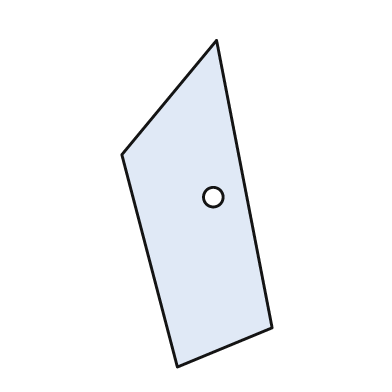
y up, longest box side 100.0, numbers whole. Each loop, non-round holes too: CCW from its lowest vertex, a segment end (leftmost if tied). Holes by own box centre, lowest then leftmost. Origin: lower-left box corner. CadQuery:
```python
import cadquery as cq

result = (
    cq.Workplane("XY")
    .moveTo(17.0, 0.0)
    .lineTo(46.0, 12.0)
    .lineTo(29.0, 100.0)
    .lineTo(0.0, 65.0)
    .close()
    .moveTo(28.0, 52.0)
    .circle(3.0)
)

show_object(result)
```